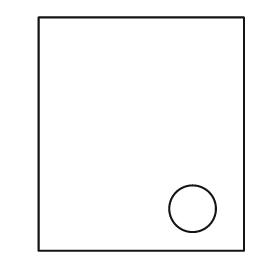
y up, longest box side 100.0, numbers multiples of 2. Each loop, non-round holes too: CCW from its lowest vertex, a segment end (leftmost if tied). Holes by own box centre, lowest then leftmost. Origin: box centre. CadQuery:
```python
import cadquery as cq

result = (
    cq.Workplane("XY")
    .moveTo(-44.0, -50.0)
    .lineTo(44.0, -50.0)
    .lineTo(44.0, 50.0)
    .lineTo(-44.0, 50.0)
    .close()
    .moveTo(22.0, -32.0)
    .circle(10.0)
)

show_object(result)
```